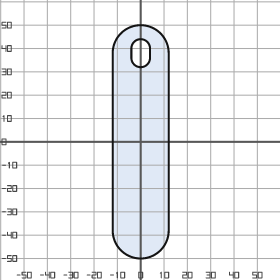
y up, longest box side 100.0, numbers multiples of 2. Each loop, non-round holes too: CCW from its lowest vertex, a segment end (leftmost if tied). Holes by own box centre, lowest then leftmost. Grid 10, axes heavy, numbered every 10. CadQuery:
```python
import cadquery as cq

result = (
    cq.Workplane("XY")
    .moveTo(-12.0, -38.0)
    .threePointArc((0.0, -50.0), (12.0, -38.0))
    .lineTo(12.0, 38.0)
    .threePointArc((0.0, 50.0), (-12.0, 38.0))
    .close()
    .moveTo(-4.0, 36.0)
    .threePointArc((0.0, 32.0), (4.0, 36.0))
    .lineTo(4.0, 40.0)
    .threePointArc((0.0, 44.0), (-4.0, 40.0))
    .close()
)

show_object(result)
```